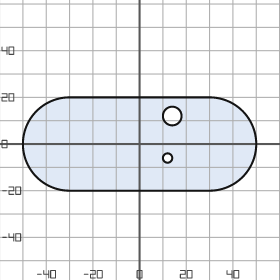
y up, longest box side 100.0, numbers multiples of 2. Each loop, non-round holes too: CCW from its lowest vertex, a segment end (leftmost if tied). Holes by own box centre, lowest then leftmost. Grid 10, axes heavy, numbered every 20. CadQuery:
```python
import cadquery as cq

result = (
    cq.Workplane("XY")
    .moveTo(-30.0, -20.0)
    .lineTo(30.0, -20.0)
    .threePointArc((50.0, 0.0), (30.0, 20.0))
    .lineTo(-30.0, 20.0)
    .threePointArc((-50.0, 0.0), (-30.0, -20.0))
    .close()
    .moveTo(12.0, -6.0)
    .circle(2.0)
    .moveTo(14.0, 12.0)
    .circle(4.0)
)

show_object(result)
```